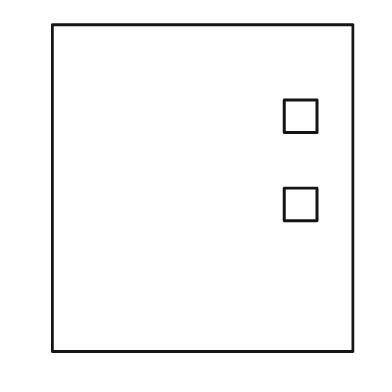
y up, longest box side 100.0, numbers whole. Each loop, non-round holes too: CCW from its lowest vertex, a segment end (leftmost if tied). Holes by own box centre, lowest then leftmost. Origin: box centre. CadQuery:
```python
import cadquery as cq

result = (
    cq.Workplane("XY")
    .moveTo(-46.0, -50.0)
    .lineTo(46.0, -50.0)
    .lineTo(46.0, 50.0)
    .lineTo(-46.0, 50.0)
    .close()
    .moveTo(25.0, -10.0)
    .lineTo(35.0, -10.0)
    .lineTo(35.0, 0.0)
    .lineTo(25.0, 0.0)
    .close()
    .moveTo(25.0, 17.0)
    .lineTo(35.0, 17.0)
    .lineTo(35.0, 27.0)
    .lineTo(25.0, 27.0)
    .close()
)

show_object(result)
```